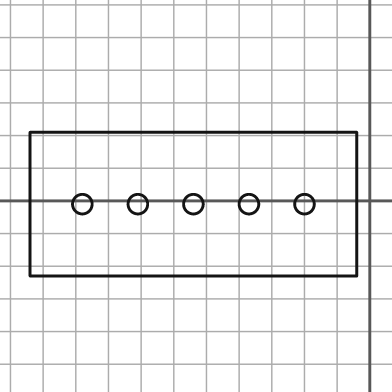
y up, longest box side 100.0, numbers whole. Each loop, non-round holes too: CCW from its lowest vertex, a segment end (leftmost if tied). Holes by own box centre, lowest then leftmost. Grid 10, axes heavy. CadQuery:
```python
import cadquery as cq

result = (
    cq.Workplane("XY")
    .moveTo(-104.0, -23.0)
    .lineTo(-4.0, -23.0)
    .lineTo(-4.0, 21.0)
    .lineTo(-104.0, 21.0)
    .close()
    .moveTo(-88.0, -1.0)
    .circle(3.0)
    .moveTo(-71.0, -1.0)
    .circle(3.0)
    .moveTo(-54.0, -1.0)
    .circle(3.0)
    .moveTo(-37.0, -1.0)
    .circle(3.0)
    .moveTo(-20.0, -1.0)
    .circle(3.0)
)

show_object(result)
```